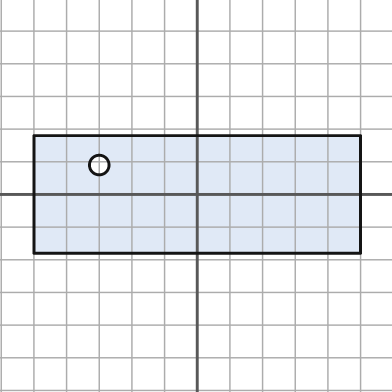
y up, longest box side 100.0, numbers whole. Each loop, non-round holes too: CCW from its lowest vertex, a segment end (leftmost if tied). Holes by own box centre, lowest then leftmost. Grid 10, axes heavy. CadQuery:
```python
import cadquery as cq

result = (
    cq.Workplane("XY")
    .moveTo(-50.0, -18.0)
    .lineTo(50.0, -18.0)
    .lineTo(50.0, 18.0)
    .lineTo(-50.0, 18.0)
    .close()
    .moveTo(-30.0, 9.0)
    .circle(3.0)
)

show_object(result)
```